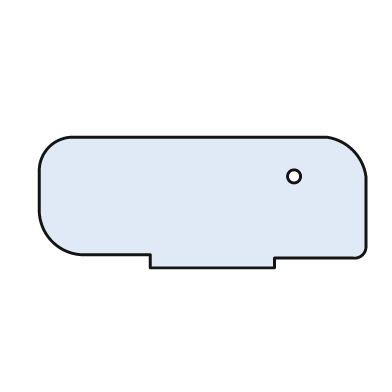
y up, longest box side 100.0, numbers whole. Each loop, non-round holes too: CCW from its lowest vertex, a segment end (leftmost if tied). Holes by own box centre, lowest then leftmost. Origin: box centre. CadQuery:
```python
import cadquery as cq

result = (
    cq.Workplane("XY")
    .moveTo(-16.0, -20.0)
    .lineTo(22.0, -20.0)
    .lineTo(22.0, -17.0)
    .lineTo(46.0, -17.0)
    .threePointArc((49.0, -16.0), (50.0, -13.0))
    .lineTo(50.0, 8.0)
    .threePointArc((46.0, 16.0), (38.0, 20.0))
    .lineTo(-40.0, 20.0)
    .threePointArc((-47.0, 17.0), (-50.0, 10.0))
    .lineTo(-50.0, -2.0)
    .threePointArc((-46.0, -12.0), (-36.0, -16.0))
    .lineTo(-16.0, -16.0)
    .close()
    .moveTo(28.0, 8.0)
    .circle(2.0)
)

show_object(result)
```